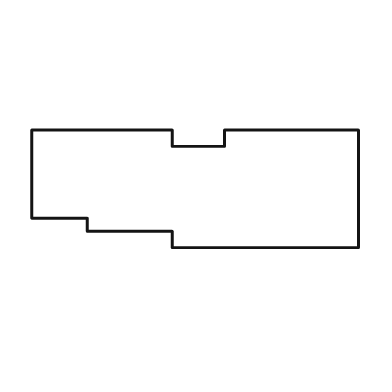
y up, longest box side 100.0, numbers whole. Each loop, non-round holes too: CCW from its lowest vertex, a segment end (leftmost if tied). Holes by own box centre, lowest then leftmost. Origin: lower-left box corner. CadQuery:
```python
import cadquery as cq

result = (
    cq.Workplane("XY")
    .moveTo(43.0, 0.0)
    .lineTo(100.0, 0.0)
    .lineTo(100.0, 36.0)
    .lineTo(59.0, 36.0)
    .lineTo(59.0, 31.0)
    .lineTo(43.0, 31.0)
    .lineTo(43.0, 36.0)
    .lineTo(0.0, 36.0)
    .lineTo(0.0, 9.0)
    .lineTo(17.0, 9.0)
    .lineTo(17.0, 5.0)
    .lineTo(43.0, 5.0)
    .close()
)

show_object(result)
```